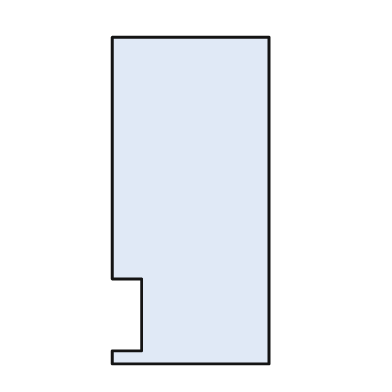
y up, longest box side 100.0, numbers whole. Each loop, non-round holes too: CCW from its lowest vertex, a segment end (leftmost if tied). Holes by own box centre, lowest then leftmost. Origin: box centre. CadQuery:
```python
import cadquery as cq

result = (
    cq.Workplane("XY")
    .moveTo(-24.0, -50.0)
    .lineTo(24.0, -50.0)
    .lineTo(24.0, 50.0)
    .lineTo(-24.0, 50.0)
    .lineTo(-24.0, -24.0)
    .lineTo(-15.0, -24.0)
    .lineTo(-15.0, -46.0)
    .lineTo(-24.0, -46.0)
    .close()
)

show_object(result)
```